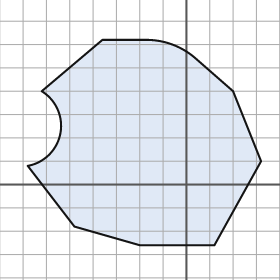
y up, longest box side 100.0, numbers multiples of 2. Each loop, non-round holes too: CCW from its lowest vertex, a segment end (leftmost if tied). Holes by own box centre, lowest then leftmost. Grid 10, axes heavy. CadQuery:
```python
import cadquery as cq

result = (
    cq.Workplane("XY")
    .moveTo(-20.0, -26.0)
    .lineTo(12.0, -26.0)
    .lineTo(32.0, 10.0)
    .lineTo(20.0, 40.0)
    .lineTo(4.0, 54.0)
    .threePointArc((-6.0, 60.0), (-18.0, 62.0))
    .lineTo(-36.0, 62.0)
    .lineTo(-62.0, 40.0)
    .threePointArc((-54.0, 22.0), (-68.0, 8.0))
    .lineTo(-48.0, -18.0)
    .close()
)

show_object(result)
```